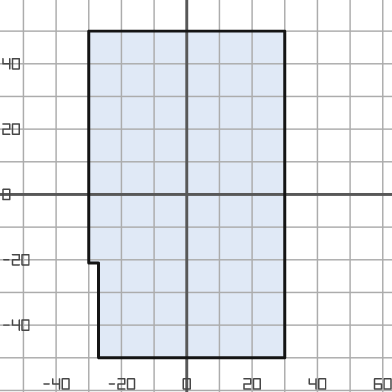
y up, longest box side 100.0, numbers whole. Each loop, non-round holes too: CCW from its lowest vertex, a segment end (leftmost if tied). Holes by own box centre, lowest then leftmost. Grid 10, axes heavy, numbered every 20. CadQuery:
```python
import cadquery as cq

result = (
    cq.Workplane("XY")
    .moveTo(-27.0, -50.0)
    .lineTo(30.0, -50.0)
    .lineTo(30.0, 50.0)
    .lineTo(-30.0, 50.0)
    .lineTo(-30.0, -21.0)
    .lineTo(-27.0, -21.0)
    .close()
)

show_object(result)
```